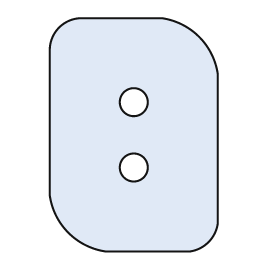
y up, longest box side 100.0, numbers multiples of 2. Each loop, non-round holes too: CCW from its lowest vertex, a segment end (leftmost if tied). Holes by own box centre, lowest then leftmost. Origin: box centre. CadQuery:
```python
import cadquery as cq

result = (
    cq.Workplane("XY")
    .moveTo(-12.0, -50.0)
    .lineTo(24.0, -50.0)
    .threePointArc((32.0, -46.0), (36.0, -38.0))
    .lineTo(36.0, 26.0)
    .threePointArc((28.0, 42.0), (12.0, 50.0))
    .lineTo(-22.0, 50.0)
    .threePointArc((-32.0, 46.0), (-36.0, 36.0))
    .lineTo(-36.0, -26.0)
    .threePointArc((-28.0, -42.0), (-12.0, -50.0))
    .close()
    .moveTo(0.0, -14.0)
    .circle(6.0)
    .moveTo(0.0, 14.0)
    .circle(6.0)
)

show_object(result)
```